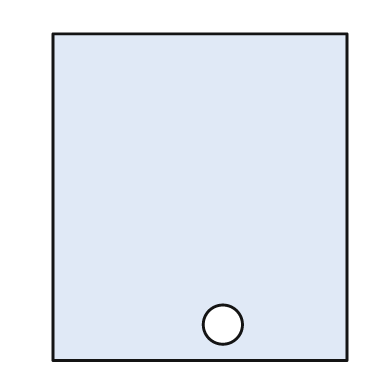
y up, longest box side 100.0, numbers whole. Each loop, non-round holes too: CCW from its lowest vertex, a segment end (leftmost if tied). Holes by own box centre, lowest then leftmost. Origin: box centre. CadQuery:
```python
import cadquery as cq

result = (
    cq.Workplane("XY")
    .moveTo(-45.0, -50.0)
    .lineTo(45.0, -50.0)
    .lineTo(45.0, 50.0)
    .lineTo(-45.0, 50.0)
    .close()
    .moveTo(7.0, -39.0)
    .circle(6.0)
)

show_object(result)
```